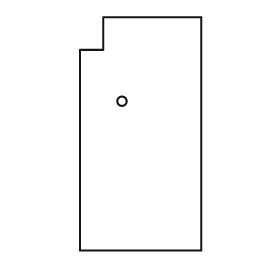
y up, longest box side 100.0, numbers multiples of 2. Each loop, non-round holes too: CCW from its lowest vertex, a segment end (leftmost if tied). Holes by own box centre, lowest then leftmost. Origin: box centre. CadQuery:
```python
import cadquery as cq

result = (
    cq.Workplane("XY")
    .moveTo(-26.0, -50.0)
    .lineTo(26.0, -50.0)
    .lineTo(26.0, 50.0)
    .lineTo(-16.0, 50.0)
    .lineTo(-16.0, 36.0)
    .lineTo(-26.0, 36.0)
    .close()
    .moveTo(-8.0, 14.0)
    .circle(2.0)
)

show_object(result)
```